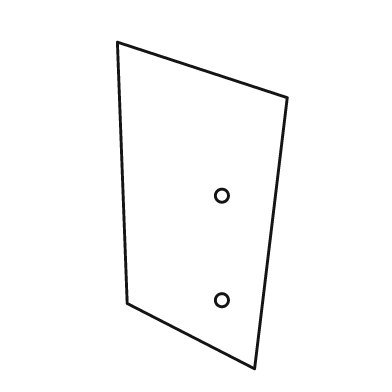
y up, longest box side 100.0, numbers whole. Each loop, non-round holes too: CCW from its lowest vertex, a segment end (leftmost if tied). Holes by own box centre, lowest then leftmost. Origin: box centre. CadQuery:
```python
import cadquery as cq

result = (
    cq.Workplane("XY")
    .moveTo(16.0, -50.0)
    .lineTo(26.0, 33.0)
    .lineTo(-26.0, 50.0)
    .lineTo(-23.0, -30.0)
    .close()
    .moveTo(6.0, -29.0)
    .circle(2.0)
    .moveTo(6.0, 3.0)
    .circle(2.0)
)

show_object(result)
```